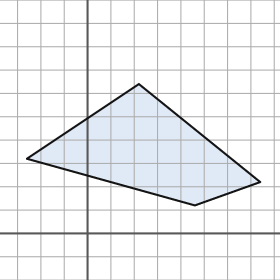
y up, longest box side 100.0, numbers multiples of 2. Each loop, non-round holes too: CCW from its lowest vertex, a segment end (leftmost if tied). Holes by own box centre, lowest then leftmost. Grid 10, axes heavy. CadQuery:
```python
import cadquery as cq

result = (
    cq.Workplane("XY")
    .moveTo(46.0, 12.0)
    .lineTo(74.0, 22.0)
    .lineTo(22.0, 64.0)
    .lineTo(-26.0, 32.0)
    .close()
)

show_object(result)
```